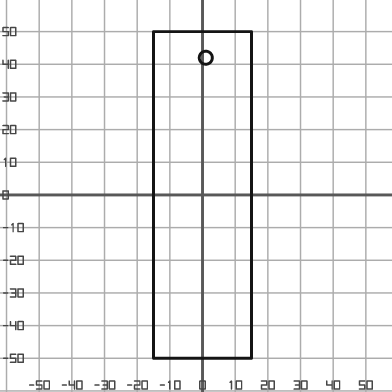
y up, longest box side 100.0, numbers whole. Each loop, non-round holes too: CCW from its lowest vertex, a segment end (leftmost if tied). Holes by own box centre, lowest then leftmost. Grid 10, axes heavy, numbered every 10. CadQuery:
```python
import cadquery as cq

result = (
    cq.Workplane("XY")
    .moveTo(-15.0, -50.0)
    .lineTo(15.0, -50.0)
    .lineTo(15.0, 50.0)
    .lineTo(-15.0, 50.0)
    .close()
    .moveTo(1.0, 42.0)
    .circle(2.0)
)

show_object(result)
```